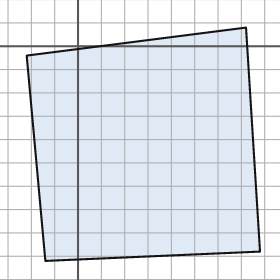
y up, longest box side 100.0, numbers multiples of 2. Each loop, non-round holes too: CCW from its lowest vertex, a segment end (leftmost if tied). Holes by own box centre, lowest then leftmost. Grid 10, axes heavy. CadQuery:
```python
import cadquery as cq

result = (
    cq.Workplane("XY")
    .moveTo(-14.0, -92.0)
    .lineTo(78.0, -88.0)
    .lineTo(72.0, 8.0)
    .lineTo(-22.0, -4.0)
    .close()
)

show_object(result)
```